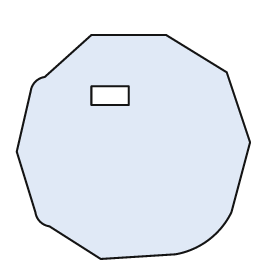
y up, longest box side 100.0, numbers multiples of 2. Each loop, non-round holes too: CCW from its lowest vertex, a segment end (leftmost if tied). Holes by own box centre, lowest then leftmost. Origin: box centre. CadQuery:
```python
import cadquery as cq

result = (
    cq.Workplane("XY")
    .moveTo(-14.0, -48.0)
    .lineTo(18.0, -46.0)
    .threePointArc((32.0, -40.0), (42.0, -28.0))
    .lineTo(50.0, 2.0)
    .lineTo(40.0, 32.0)
    .lineTo(14.0, 48.0)
    .lineTo(-18.0, 48.0)
    .lineTo(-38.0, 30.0)
    .threePointArc((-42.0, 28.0), (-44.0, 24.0))
    .lineTo(-50.0, -2.0)
    .lineTo(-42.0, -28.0)
    .threePointArc((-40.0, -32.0), (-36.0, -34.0))
    .close()
    .moveTo(-18.0, 18.0)
    .lineTo(-2.0, 18.0)
    .lineTo(-2.0, 26.0)
    .lineTo(-18.0, 26.0)
    .close()
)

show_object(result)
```